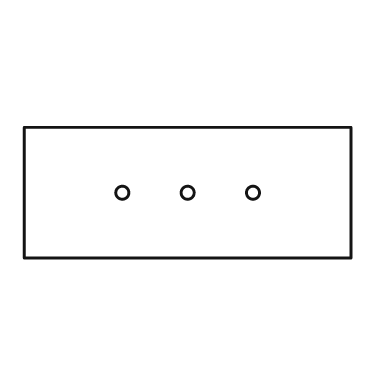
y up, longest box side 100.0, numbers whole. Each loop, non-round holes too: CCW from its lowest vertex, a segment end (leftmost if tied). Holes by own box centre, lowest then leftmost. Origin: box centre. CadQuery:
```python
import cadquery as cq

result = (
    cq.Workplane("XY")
    .moveTo(-50.0, -20.0)
    .lineTo(50.0, -20.0)
    .lineTo(50.0, 20.0)
    .lineTo(-50.0, 20.0)
    .close()
    .moveTo(-20.0, 0.0)
    .circle(2.0)
    .moveTo(0.0, 0.0)
    .circle(2.0)
    .moveTo(20.0, 0.0)
    .circle(2.0)
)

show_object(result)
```